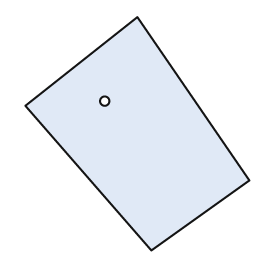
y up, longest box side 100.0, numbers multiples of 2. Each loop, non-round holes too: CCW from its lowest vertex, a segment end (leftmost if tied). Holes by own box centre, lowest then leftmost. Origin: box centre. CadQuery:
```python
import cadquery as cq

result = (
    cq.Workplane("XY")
    .moveTo(6.0, -50.0)
    .lineTo(48.0, -20.0)
    .lineTo(0.0, 50.0)
    .lineTo(-48.0, 12.0)
    .close()
    .moveTo(-14.0, 14.0)
    .circle(2.0)
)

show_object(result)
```